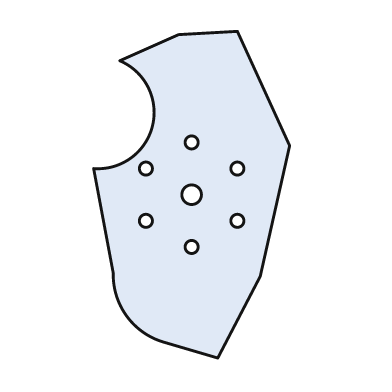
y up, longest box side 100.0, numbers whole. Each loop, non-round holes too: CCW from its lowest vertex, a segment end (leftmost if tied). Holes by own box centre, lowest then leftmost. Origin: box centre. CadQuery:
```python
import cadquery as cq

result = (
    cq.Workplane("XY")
    .moveTo(8.0, -50.0)
    .lineTo(21.0, -25.0)
    .lineTo(30.0, 15.0)
    .lineTo(14.0, 50.0)
    .lineTo(-4.0, 49.0)
    .lineTo(-22.0, 41.0)
    .threePointArc((-12.0, 21.0), (-30.0, 8.0))
    .lineTo(-24.0, -24.0)
    .threePointArc((-20.0, -37.0), (-9.0, -45.0))
    .close()
    .moveTo(0.0, -16.0)
    .circle(2.0)
    .moveTo(-14.0, -8.0)
    .circle(2.0)
    .moveTo(14.0, -8.0)
    .circle(2.0)
    .moveTo(0.0, 0.0)
    .circle(3.0)
    .moveTo(-14.0, 8.0)
    .circle(2.0)
    .moveTo(14.0, 8.0)
    .circle(2.0)
    .moveTo(0.0, 16.0)
    .circle(2.0)
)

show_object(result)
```